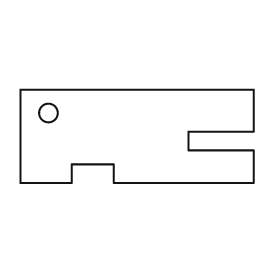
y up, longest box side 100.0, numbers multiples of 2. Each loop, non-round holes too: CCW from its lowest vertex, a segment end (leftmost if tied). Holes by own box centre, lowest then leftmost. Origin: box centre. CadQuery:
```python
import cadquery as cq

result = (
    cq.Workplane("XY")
    .moveTo(-50.0, -20.0)
    .lineTo(-28.0, -20.0)
    .lineTo(-28.0, -12.0)
    .lineTo(-10.0, -12.0)
    .lineTo(-10.0, -20.0)
    .lineTo(50.0, -20.0)
    .lineTo(50.0, -6.0)
    .lineTo(22.0, -6.0)
    .lineTo(22.0, 2.0)
    .lineTo(50.0, 2.0)
    .lineTo(50.0, 20.0)
    .lineTo(-50.0, 20.0)
    .close()
    .moveTo(-38.0, 10.0)
    .circle(4.0)
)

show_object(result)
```